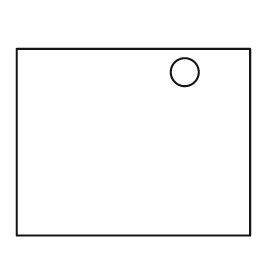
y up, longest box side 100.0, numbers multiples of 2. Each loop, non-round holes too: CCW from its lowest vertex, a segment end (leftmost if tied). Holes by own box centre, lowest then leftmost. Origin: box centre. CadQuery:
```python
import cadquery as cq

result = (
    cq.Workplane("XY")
    .moveTo(-50.0, -40.0)
    .lineTo(50.0, -40.0)
    .lineTo(50.0, 40.0)
    .lineTo(-50.0, 40.0)
    .close()
    .moveTo(22.0, 30.0)
    .circle(6.0)
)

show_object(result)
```